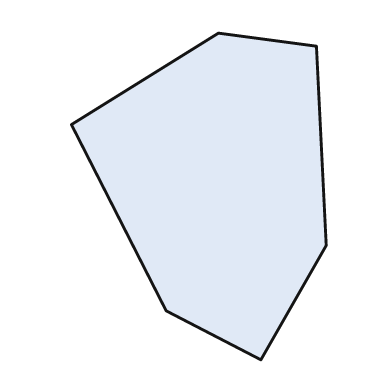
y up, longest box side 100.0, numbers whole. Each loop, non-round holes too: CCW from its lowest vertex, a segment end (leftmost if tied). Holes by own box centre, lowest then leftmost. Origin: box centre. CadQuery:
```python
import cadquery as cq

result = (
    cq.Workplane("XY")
    .moveTo(19.0, -50.0)
    .lineTo(39.0, -15.0)
    .lineTo(36.0, 46.0)
    .lineTo(6.0, 50.0)
    .lineTo(-39.0, 22.0)
    .lineTo(-10.0, -35.0)
    .close()
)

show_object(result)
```